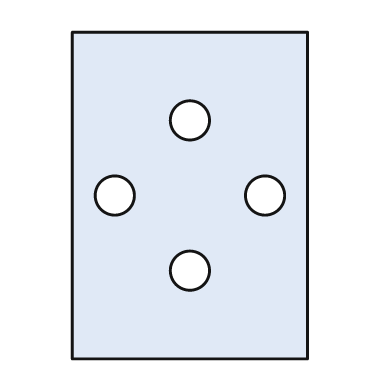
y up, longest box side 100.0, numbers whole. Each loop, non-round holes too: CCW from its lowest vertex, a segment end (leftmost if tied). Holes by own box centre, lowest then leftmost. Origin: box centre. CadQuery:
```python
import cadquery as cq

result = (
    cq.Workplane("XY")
    .moveTo(-36.0, -50.0)
    .lineTo(36.0, -50.0)
    .lineTo(36.0, 50.0)
    .lineTo(-36.0, 50.0)
    .close()
    .moveTo(0.0, -23.0)
    .circle(6.0)
    .moveTo(-23.0, 0.0)
    .circle(6.0)
    .moveTo(23.0, 0.0)
    .circle(6.0)
    .moveTo(0.0, 23.0)
    .circle(6.0)
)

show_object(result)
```